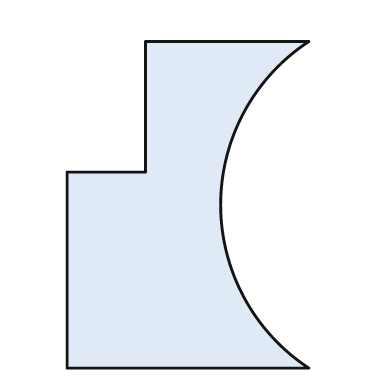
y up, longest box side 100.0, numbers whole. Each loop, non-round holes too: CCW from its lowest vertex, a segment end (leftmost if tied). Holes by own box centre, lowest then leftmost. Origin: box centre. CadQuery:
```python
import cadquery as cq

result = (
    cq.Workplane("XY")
    .moveTo(-37.0, -50.0)
    .lineTo(37.0, -50.0)
    .threePointArc((10.0, 0.0), (37.0, 50.0))
    .lineTo(-13.0, 50.0)
    .lineTo(-13.0, 10.0)
    .lineTo(-37.0, 10.0)
    .close()
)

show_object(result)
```